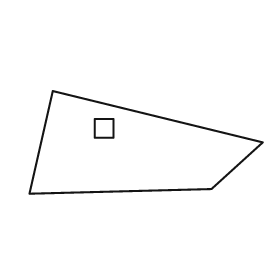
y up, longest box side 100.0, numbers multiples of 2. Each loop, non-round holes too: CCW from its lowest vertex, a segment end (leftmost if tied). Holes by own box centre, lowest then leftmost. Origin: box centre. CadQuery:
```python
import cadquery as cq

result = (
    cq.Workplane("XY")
    .moveTo(-50.0, -22.0)
    .lineTo(28.0, -20.0)
    .lineTo(50.0, 0.0)
    .lineTo(-40.0, 22.0)
    .close()
    .moveTo(-22.0, 2.0)
    .lineTo(-14.0, 2.0)
    .lineTo(-14.0, 10.0)
    .lineTo(-22.0, 10.0)
    .close()
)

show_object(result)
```